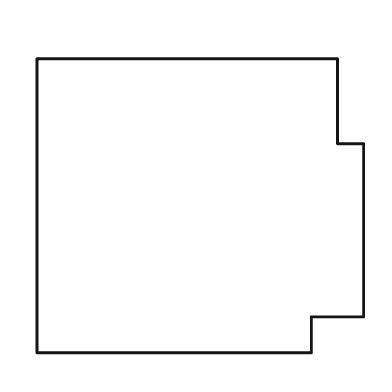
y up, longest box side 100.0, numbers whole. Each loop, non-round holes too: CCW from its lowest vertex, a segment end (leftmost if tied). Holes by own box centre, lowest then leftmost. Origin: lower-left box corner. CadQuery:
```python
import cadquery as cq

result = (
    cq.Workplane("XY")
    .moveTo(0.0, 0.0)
    .lineTo(84.0, 0.0)
    .lineTo(84.0, 11.0)
    .lineTo(100.0, 11.0)
    .lineTo(100.0, 64.0)
    .lineTo(92.0, 64.0)
    .lineTo(92.0, 90.0)
    .lineTo(0.0, 90.0)
    .close()
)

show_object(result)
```